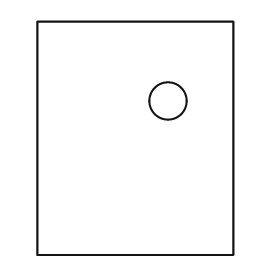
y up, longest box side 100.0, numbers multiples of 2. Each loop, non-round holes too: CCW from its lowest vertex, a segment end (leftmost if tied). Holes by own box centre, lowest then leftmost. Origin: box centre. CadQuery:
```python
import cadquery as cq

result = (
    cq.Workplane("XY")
    .moveTo(-42.0, -50.0)
    .lineTo(42.0, -50.0)
    .lineTo(42.0, 50.0)
    .lineTo(-42.0, 50.0)
    .close()
    .moveTo(14.0, 16.0)
    .circle(8.0)
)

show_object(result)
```